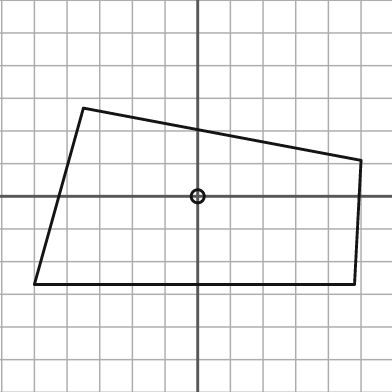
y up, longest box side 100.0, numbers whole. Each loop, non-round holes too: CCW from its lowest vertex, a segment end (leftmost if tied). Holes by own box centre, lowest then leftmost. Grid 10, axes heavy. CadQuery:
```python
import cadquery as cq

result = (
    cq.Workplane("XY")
    .moveTo(-50.0, -27.0)
    .lineTo(48.0, -27.0)
    .lineTo(50.0, 11.0)
    .lineTo(-35.0, 27.0)
    .close()
    .moveTo(0.0, 0.0)
    .circle(2.0)
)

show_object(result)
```